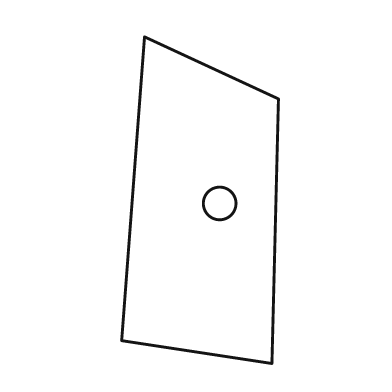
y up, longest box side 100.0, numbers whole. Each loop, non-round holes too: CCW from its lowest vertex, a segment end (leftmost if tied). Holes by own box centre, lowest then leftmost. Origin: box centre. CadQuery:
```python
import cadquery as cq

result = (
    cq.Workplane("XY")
    .moveTo(22.0, -50.0)
    .lineTo(24.0, 31.0)
    .lineTo(-17.0, 50.0)
    .lineTo(-24.0, -43.0)
    .close()
    .moveTo(6.0, -1.0)
    .circle(5.0)
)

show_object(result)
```